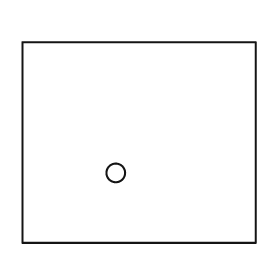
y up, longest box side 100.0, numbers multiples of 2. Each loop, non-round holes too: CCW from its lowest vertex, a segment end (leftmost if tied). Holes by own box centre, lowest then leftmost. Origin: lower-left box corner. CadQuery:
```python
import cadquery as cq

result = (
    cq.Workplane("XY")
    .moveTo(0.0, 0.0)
    .lineTo(100.0, 0.0)
    .lineTo(100.0, 86.0)
    .lineTo(0.0, 86.0)
    .close()
    .moveTo(40.0, 30.0)
    .circle(4.0)
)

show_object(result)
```